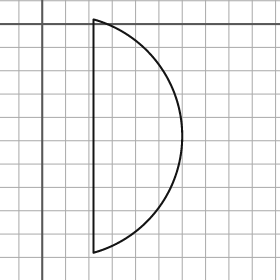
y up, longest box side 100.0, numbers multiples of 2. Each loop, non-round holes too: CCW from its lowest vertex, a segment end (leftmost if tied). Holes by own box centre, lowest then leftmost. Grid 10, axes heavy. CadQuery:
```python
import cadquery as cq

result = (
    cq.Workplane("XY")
    .moveTo(22.0, -98.0)
    .threePointArc((60.0, -48.0), (22.0, 2.0))
    .close()
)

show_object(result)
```